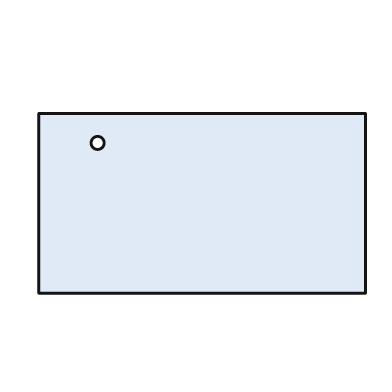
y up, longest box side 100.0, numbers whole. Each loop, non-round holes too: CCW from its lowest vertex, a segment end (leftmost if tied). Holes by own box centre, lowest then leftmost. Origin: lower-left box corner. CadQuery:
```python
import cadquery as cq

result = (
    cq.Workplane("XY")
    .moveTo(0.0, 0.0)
    .lineTo(100.0, 0.0)
    .lineTo(100.0, 55.0)
    .lineTo(0.0, 55.0)
    .close()
    .moveTo(18.0, 46.0)
    .circle(2.0)
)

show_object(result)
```